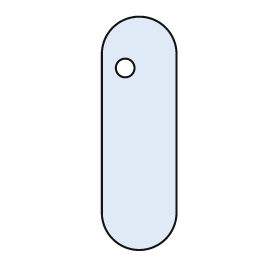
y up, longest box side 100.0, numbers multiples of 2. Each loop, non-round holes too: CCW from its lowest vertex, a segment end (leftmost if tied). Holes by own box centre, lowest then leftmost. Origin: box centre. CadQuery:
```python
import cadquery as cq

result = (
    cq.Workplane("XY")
    .moveTo(-16.0, -34.0)
    .threePointArc((0.0, -50.0), (16.0, -34.0))
    .lineTo(16.0, 34.0)
    .threePointArc((0.0, 50.0), (-16.0, 34.0))
    .close()
    .moveTo(-6.0, 28.0)
    .circle(4.0)
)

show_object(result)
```